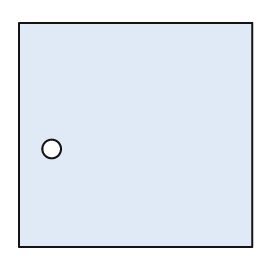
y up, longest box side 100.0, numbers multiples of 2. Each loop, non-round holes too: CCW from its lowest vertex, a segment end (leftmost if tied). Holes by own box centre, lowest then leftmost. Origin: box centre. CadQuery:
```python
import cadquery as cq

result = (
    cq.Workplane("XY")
    .moveTo(-50.0, -48.0)
    .lineTo(50.0, -48.0)
    .lineTo(50.0, 48.0)
    .lineTo(-50.0, 48.0)
    .close()
    .moveTo(-36.0, -6.0)
    .circle(4.0)
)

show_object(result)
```